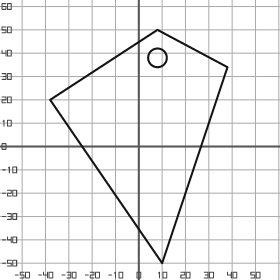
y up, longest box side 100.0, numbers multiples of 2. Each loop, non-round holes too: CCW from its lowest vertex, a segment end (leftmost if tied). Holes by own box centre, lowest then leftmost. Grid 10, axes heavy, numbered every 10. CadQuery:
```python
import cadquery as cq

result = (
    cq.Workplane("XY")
    .moveTo(10.0, -50.0)
    .lineTo(38.0, 34.0)
    .lineTo(8.0, 50.0)
    .lineTo(-38.0, 20.0)
    .close()
    .moveTo(8.0, 38.0)
    .circle(4.0)
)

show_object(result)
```